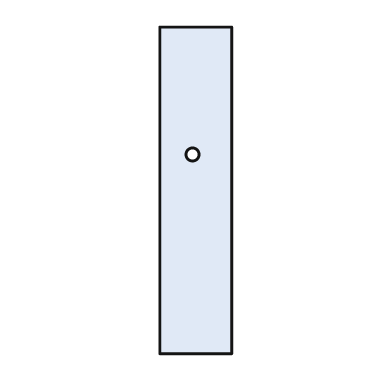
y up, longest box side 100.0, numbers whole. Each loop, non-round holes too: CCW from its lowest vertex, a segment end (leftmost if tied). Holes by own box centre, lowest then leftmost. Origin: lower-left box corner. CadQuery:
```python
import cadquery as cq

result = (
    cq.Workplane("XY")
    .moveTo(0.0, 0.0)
    .lineTo(22.0, 0.0)
    .lineTo(22.0, 100.0)
    .lineTo(0.0, 100.0)
    .close()
    .moveTo(10.0, 61.0)
    .circle(2.0)
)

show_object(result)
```